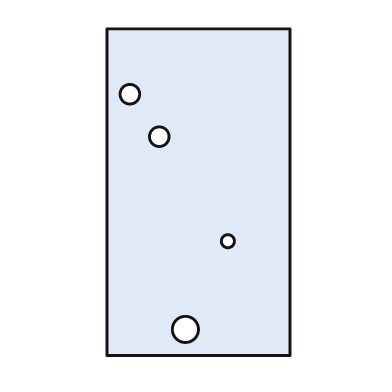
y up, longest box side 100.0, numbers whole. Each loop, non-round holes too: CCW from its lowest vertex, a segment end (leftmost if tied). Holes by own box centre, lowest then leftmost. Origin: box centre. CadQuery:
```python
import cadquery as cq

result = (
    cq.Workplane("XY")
    .moveTo(-28.0, -50.0)
    .lineTo(28.0, -50.0)
    .lineTo(28.0, 50.0)
    .lineTo(-28.0, 50.0)
    .close()
    .moveTo(-4.0, -42.0)
    .circle(4.0)
    .moveTo(9.0, -15.0)
    .circle(2.0)
    .moveTo(-12.0, 17.0)
    .circle(3.0)
    .moveTo(-21.0, 30.0)
    .circle(3.0)
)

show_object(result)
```